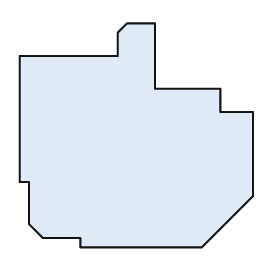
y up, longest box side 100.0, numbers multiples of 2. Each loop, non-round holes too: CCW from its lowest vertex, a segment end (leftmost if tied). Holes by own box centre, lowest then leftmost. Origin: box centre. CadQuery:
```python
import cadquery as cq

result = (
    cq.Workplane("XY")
    .moveTo(-24.0, -48.0)
    .lineTo(28.0, -48.0)
    .lineTo(50.0, -26.0)
    .lineTo(50.0, 10.0)
    .lineTo(36.0, 10.0)
    .lineTo(36.0, 20.0)
    .lineTo(8.0, 20.0)
    .lineTo(8.0, 48.0)
    .lineTo(-4.0, 48.0)
    .lineTo(-8.0, 44.0)
    .lineTo(-8.0, 34.0)
    .lineTo(-50.0, 34.0)
    .lineTo(-50.0, -20.0)
    .lineTo(-46.0, -20.0)
    .lineTo(-46.0, -38.0)
    .lineTo(-40.0, -44.0)
    .lineTo(-24.0, -44.0)
    .close()
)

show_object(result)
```